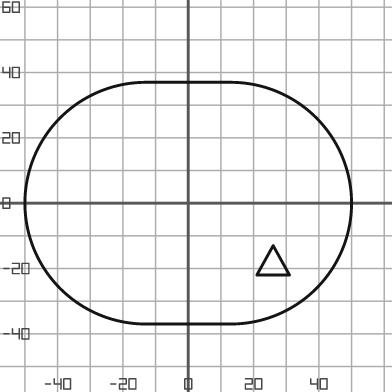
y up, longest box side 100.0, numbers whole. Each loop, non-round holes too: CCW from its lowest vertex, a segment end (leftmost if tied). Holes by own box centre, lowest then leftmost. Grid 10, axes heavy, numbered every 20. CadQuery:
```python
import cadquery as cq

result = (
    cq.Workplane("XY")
    .moveTo(-13.0, -37.0)
    .lineTo(13.0, -37.0)
    .threePointArc((50.0, 0.0), (13.0, 37.0))
    .lineTo(-13.0, 37.0)
    .threePointArc((-50.0, 0.0), (-13.0, -37.0))
    .close()
    .moveTo(21.0, -22.0)
    .lineTo(31.0, -22.0)
    .lineTo(26.0, -13.0)
    .close()
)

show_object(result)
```